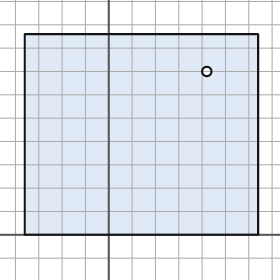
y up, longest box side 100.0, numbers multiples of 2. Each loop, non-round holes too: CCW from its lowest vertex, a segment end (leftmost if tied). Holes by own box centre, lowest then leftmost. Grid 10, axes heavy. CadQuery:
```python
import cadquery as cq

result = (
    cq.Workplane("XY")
    .moveTo(-36.0, 0.0)
    .lineTo(64.0, 0.0)
    .lineTo(64.0, 86.0)
    .lineTo(-36.0, 86.0)
    .close()
    .moveTo(42.0, 70.0)
    .circle(2.0)
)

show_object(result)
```